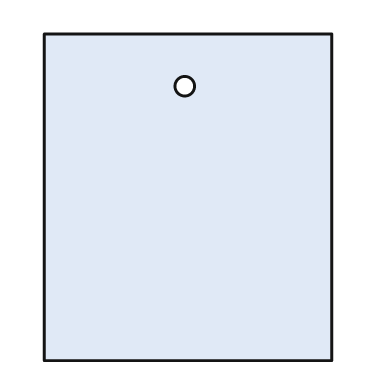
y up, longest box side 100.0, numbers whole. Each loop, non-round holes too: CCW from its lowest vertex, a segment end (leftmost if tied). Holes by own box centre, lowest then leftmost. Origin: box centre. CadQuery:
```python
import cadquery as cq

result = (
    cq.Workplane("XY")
    .moveTo(-44.0, -50.0)
    .lineTo(44.0, -50.0)
    .lineTo(44.0, 50.0)
    .lineTo(-44.0, 50.0)
    .close()
    .moveTo(-1.0, 34.0)
    .circle(3.0)
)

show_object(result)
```